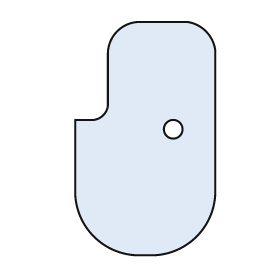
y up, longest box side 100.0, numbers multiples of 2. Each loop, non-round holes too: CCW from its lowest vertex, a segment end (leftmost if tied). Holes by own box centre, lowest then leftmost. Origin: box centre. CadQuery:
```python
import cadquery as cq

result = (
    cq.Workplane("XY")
    .moveTo(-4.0, -50.0)
    .lineTo(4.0, -50.0)
    .threePointArc((22.0, -42.0), (30.0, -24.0))
    .lineTo(30.0, 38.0)
    .threePointArc((26.0, 46.0), (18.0, 50.0))
    .lineTo(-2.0, 50.0)
    .threePointArc((-12.0, 46.0), (-16.0, 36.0))
    .lineTo(-16.0, 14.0)
    .threePointArc((-18.0, 10.0), (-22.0, 8.0))
    .lineTo(-30.0, 8.0)
    .lineTo(-30.0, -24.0)
    .threePointArc((-22.0, -42.0), (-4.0, -50.0))
    .close()
    .moveTo(12.0, 4.0)
    .circle(4.0)
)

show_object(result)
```